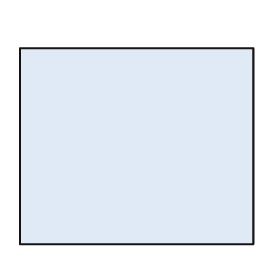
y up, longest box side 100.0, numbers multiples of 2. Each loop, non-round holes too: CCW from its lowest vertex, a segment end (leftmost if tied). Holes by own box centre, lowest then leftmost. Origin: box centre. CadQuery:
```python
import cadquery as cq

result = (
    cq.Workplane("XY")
    .moveTo(-50.0, -42.0)
    .lineTo(50.0, -42.0)
    .lineTo(50.0, 42.0)
    .lineTo(-50.0, 42.0)
    .close()
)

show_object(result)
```